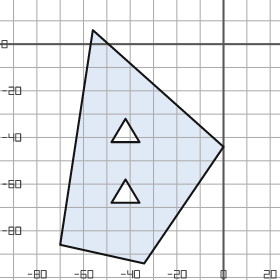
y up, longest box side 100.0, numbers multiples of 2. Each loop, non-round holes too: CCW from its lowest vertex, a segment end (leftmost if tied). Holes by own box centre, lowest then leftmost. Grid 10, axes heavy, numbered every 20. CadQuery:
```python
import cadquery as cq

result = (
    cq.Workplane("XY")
    .moveTo(-34.0, -94.0)
    .lineTo(0.0, -44.0)
    .lineTo(-56.0, 6.0)
    .lineTo(-70.0, -86.0)
    .close()
    .moveTo(-48.0, -68.0)
    .lineTo(-36.0, -68.0)
    .lineTo(-42.0, -58.0)
    .close()
    .moveTo(-48.0, -42.0)
    .lineTo(-36.0, -42.0)
    .lineTo(-42.0, -32.0)
    .close()
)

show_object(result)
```